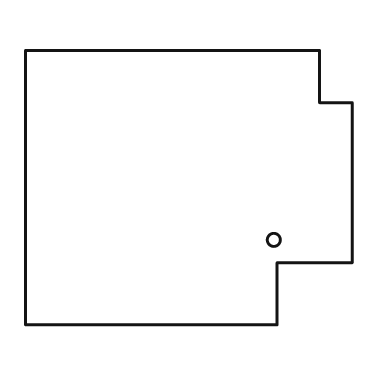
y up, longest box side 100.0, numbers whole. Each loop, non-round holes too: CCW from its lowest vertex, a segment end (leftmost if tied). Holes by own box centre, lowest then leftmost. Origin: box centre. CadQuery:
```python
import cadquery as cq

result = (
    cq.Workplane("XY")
    .moveTo(-50.0, -42.0)
    .lineTo(27.0, -42.0)
    .lineTo(27.0, -23.0)
    .lineTo(50.0, -23.0)
    .lineTo(50.0, 26.0)
    .lineTo(40.0, 26.0)
    .lineTo(40.0, 42.0)
    .lineTo(-50.0, 42.0)
    .close()
    .moveTo(26.0, -16.0)
    .circle(2.0)
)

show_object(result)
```